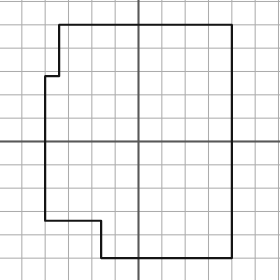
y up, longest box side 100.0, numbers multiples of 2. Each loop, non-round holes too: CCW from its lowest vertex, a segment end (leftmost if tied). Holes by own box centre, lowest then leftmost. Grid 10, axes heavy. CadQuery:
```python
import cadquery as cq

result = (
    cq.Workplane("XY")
    .moveTo(-16.0, -50.0)
    .lineTo(40.0, -50.0)
    .lineTo(40.0, 50.0)
    .lineTo(-34.0, 50.0)
    .lineTo(-34.0, 28.0)
    .lineTo(-40.0, 28.0)
    .lineTo(-40.0, -34.0)
    .lineTo(-16.0, -34.0)
    .close()
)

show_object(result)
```